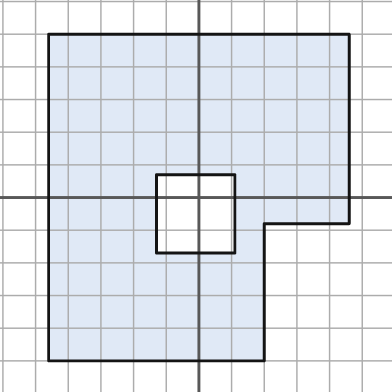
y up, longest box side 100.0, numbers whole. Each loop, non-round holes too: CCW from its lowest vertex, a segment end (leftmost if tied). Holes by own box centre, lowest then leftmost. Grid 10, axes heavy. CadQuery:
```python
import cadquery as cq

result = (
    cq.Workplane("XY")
    .moveTo(-46.0, -50.0)
    .lineTo(20.0, -50.0)
    .lineTo(20.0, -8.0)
    .lineTo(46.0, -8.0)
    .lineTo(46.0, 50.0)
    .lineTo(-46.0, 50.0)
    .close()
    .moveTo(-13.0, -17.0)
    .lineTo(11.0, -17.0)
    .lineTo(11.0, 7.0)
    .lineTo(-13.0, 7.0)
    .close()
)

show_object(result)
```